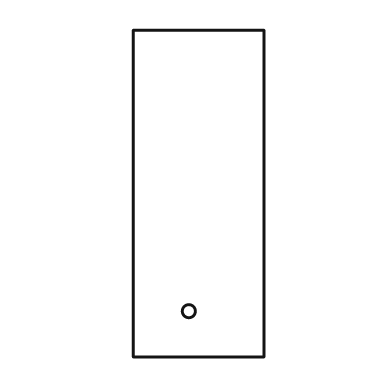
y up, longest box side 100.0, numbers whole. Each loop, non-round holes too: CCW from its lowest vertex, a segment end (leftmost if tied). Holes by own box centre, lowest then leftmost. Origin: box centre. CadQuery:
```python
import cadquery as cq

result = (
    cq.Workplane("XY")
    .moveTo(-20.0, -50.0)
    .lineTo(20.0, -50.0)
    .lineTo(20.0, 50.0)
    .lineTo(-20.0, 50.0)
    .close()
    .moveTo(-3.0, -36.0)
    .circle(2.0)
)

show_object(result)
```